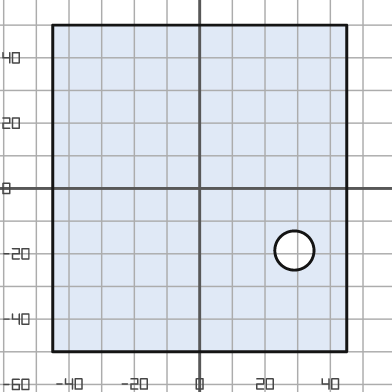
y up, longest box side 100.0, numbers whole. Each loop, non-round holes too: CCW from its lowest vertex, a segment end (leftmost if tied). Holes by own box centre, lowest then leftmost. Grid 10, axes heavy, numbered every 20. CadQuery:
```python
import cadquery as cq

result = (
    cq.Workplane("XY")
    .moveTo(-45.0, -50.0)
    .lineTo(45.0, -50.0)
    .lineTo(45.0, 50.0)
    .lineTo(-45.0, 50.0)
    .close()
    .moveTo(29.0, -19.0)
    .circle(6.0)
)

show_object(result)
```